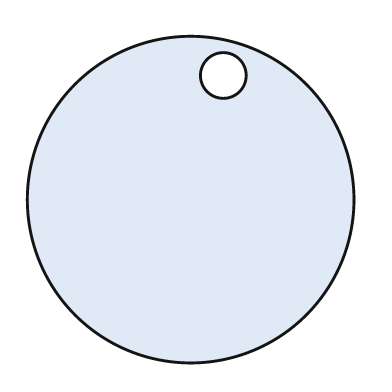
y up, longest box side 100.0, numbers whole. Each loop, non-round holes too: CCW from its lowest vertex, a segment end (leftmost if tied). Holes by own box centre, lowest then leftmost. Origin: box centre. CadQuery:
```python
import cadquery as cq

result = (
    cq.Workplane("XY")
    .moveTo(0.0, 0.0)
    .circle(50.0)
    .moveTo(10.0, 38.0)
    .circle(7.0)
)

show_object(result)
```